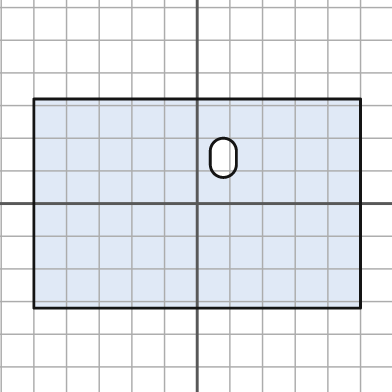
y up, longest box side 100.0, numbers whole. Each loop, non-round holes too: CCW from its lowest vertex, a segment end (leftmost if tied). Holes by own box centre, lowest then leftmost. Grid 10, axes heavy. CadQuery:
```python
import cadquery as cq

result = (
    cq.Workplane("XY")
    .moveTo(-50.0, -32.0)
    .lineTo(50.0, -32.0)
    .lineTo(50.0, 32.0)
    .lineTo(-50.0, 32.0)
    .close()
    .moveTo(4.0, 12.0)
    .threePointArc((8.0, 8.0), (12.0, 12.0))
    .lineTo(12.0, 16.0)
    .threePointArc((8.0, 20.0), (4.0, 16.0))
    .close()
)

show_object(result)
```